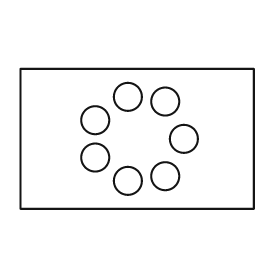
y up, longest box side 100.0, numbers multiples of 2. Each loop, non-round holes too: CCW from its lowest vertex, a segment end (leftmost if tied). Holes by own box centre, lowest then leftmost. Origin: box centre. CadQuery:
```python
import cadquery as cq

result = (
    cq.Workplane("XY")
    .moveTo(-50.0, -30.0)
    .lineTo(50.0, -30.0)
    .lineTo(50.0, 30.0)
    .lineTo(-50.0, 30.0)
    .close()
    .moveTo(-4.0, -18.0)
    .circle(6.0)
    .moveTo(12.0, -16.0)
    .circle(6.0)
    .moveTo(-18.0, -8.0)
    .circle(6.0)
    .moveTo(20.0, 0.0)
    .circle(6.0)
    .moveTo(-18.0, 8.0)
    .circle(6.0)
    .moveTo(12.0, 16.0)
    .circle(6.0)
    .moveTo(-4.0, 18.0)
    .circle(6.0)
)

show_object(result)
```